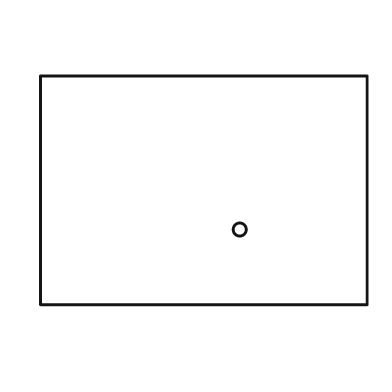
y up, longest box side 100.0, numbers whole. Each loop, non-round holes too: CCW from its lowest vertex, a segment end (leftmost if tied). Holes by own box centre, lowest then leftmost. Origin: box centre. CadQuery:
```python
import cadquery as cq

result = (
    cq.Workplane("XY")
    .moveTo(-50.0, -35.0)
    .lineTo(50.0, -35.0)
    .lineTo(50.0, 35.0)
    .lineTo(-50.0, 35.0)
    .close()
    .moveTo(11.0, -12.0)
    .circle(2.0)
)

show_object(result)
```